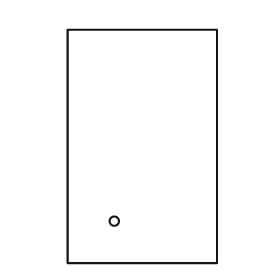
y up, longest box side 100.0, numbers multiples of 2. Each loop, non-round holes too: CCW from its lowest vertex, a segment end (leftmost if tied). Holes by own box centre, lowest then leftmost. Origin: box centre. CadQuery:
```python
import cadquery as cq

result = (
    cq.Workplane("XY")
    .moveTo(-32.0, -50.0)
    .lineTo(32.0, -50.0)
    .lineTo(32.0, 50.0)
    .lineTo(-32.0, 50.0)
    .close()
    .moveTo(-12.0, -32.0)
    .circle(2.0)
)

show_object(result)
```